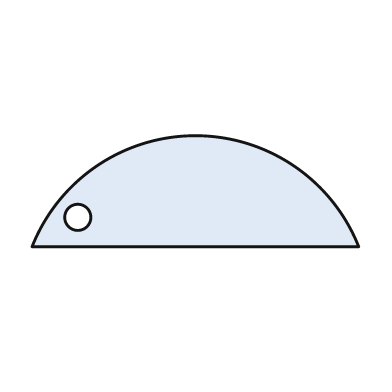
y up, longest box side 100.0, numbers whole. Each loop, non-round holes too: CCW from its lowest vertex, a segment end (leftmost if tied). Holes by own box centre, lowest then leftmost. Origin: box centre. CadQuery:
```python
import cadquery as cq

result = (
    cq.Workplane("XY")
    .moveTo(-50.0, -17.0)
    .lineTo(50.0, -17.0)
    .threePointArc((0.0, 17.0), (-50.0, -17.0))
    .close()
    .moveTo(-36.0, -8.0)
    .circle(4.0)
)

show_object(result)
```